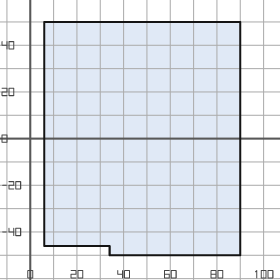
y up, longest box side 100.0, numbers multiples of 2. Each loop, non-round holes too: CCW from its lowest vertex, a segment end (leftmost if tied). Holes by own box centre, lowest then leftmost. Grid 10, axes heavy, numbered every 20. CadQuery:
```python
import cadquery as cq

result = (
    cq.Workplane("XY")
    .moveTo(34.0, -50.0)
    .lineTo(90.0, -50.0)
    .lineTo(90.0, 50.0)
    .lineTo(6.0, 50.0)
    .lineTo(6.0, -46.0)
    .lineTo(34.0, -46.0)
    .close()
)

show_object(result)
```